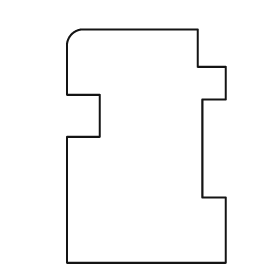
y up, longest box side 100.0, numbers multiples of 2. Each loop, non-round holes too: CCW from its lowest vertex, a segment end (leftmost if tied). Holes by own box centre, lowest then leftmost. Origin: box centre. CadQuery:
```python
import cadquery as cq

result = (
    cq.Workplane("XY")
    .moveTo(-34.0, -50.0)
    .lineTo(34.0, -50.0)
    .lineTo(34.0, -22.0)
    .lineTo(24.0, -22.0)
    .lineTo(24.0, 20.0)
    .lineTo(34.0, 20.0)
    .lineTo(34.0, 34.0)
    .lineTo(22.0, 34.0)
    .lineTo(22.0, 50.0)
    .lineTo(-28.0, 50.0)
    .threePointArc((-32.0, 48.0), (-34.0, 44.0))
    .lineTo(-34.0, 22.0)
    .lineTo(-20.0, 22.0)
    .lineTo(-20.0, 4.0)
    .lineTo(-34.0, 4.0)
    .close()
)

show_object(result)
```